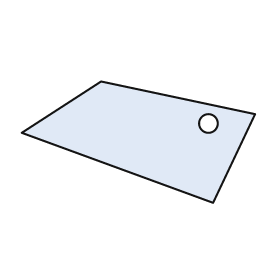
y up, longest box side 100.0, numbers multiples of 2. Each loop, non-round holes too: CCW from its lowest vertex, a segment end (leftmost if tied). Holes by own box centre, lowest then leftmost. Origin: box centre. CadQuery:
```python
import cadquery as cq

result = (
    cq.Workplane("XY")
    .moveTo(32.0, -26.0)
    .lineTo(50.0, 12.0)
    .lineTo(-16.0, 26.0)
    .lineTo(-50.0, 4.0)
    .close()
    .moveTo(30.0, 8.0)
    .circle(4.0)
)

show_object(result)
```